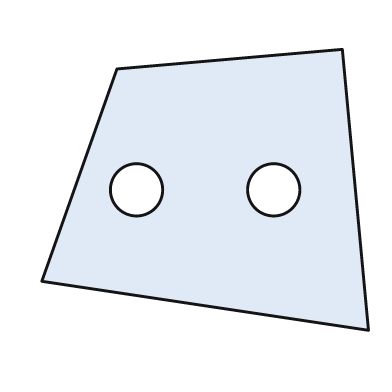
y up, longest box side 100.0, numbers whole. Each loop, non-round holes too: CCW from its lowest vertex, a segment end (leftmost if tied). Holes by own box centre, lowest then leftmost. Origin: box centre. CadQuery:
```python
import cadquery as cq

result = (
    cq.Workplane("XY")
    .moveTo(50.0, -43.0)
    .lineTo(42.0, 43.0)
    .lineTo(-27.0, 37.0)
    .lineTo(-50.0, -28.0)
    .close()
    .moveTo(-21.0, 0.0)
    .circle(8.0)
    .moveTo(21.0, 0.0)
    .circle(8.0)
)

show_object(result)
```